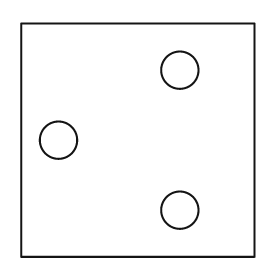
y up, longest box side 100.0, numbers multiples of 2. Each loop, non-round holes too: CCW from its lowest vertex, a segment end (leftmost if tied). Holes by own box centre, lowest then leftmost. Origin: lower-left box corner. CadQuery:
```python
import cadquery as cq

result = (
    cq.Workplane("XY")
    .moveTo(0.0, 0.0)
    .lineTo(100.0, 0.0)
    .lineTo(100.0, 100.0)
    .lineTo(0.0, 100.0)
    .close()
    .moveTo(68.0, 20.0)
    .circle(8.0)
    .moveTo(16.0, 50.0)
    .circle(8.0)
    .moveTo(68.0, 80.0)
    .circle(8.0)
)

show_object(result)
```